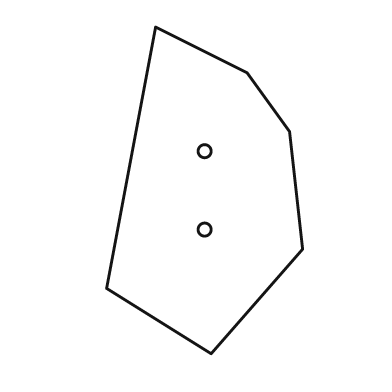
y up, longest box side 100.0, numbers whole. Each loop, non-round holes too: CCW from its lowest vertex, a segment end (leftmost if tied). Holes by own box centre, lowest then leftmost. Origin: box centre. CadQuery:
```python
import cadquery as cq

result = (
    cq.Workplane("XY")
    .moveTo(2.0, -50.0)
    .lineTo(30.0, -18.0)
    .lineTo(26.0, 18.0)
    .lineTo(13.0, 36.0)
    .lineTo(-15.0, 50.0)
    .lineTo(-30.0, -30.0)
    .close()
    .moveTo(0.0, -12.0)
    .circle(2.0)
    .moveTo(0.0, 12.0)
    .circle(2.0)
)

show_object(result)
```